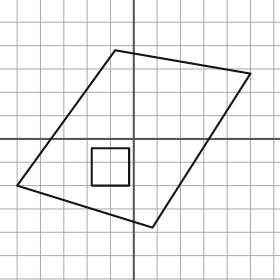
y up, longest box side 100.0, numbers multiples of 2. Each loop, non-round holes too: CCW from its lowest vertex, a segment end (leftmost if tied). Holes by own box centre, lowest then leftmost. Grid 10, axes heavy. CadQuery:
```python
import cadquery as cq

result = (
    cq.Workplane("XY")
    .moveTo(8.0, -38.0)
    .lineTo(50.0, 28.0)
    .lineTo(-8.0, 38.0)
    .lineTo(-50.0, -20.0)
    .close()
    .moveTo(-18.0, -20.0)
    .lineTo(-2.0, -20.0)
    .lineTo(-2.0, -4.0)
    .lineTo(-18.0, -4.0)
    .close()
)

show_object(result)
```